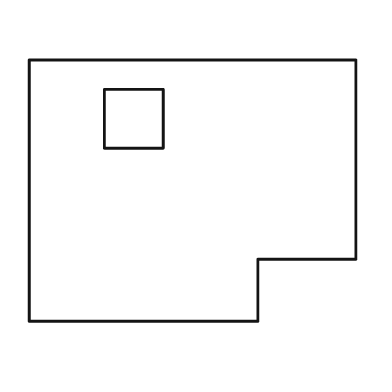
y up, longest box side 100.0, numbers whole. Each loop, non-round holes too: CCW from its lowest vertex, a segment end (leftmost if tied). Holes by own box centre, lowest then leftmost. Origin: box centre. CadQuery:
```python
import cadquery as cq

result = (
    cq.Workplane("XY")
    .moveTo(-50.0, -40.0)
    .lineTo(20.0, -40.0)
    .lineTo(20.0, -21.0)
    .lineTo(50.0, -21.0)
    .lineTo(50.0, 40.0)
    .lineTo(-50.0, 40.0)
    .close()
    .moveTo(-27.0, 13.0)
    .lineTo(-9.0, 13.0)
    .lineTo(-9.0, 31.0)
    .lineTo(-27.0, 31.0)
    .close()
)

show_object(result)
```